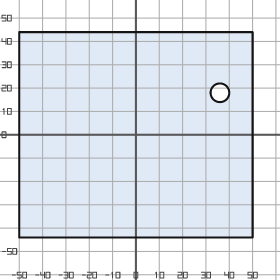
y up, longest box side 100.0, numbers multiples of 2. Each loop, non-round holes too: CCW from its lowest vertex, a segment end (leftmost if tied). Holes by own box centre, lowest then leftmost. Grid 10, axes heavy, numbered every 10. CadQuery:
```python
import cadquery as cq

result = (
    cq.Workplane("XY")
    .moveTo(-50.0, -44.0)
    .lineTo(50.0, -44.0)
    .lineTo(50.0, 44.0)
    .lineTo(-50.0, 44.0)
    .close()
    .moveTo(36.0, 18.0)
    .circle(4.0)
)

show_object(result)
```